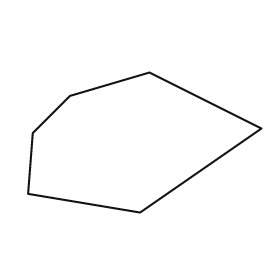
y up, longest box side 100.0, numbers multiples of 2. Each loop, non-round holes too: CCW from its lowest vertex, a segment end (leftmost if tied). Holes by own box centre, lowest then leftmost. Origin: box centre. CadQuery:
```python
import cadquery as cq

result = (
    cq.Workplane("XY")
    .moveTo(-2.0, -30.0)
    .lineTo(50.0, 6.0)
    .lineTo(2.0, 30.0)
    .lineTo(-32.0, 20.0)
    .lineTo(-48.0, 4.0)
    .lineTo(-50.0, -22.0)
    .close()
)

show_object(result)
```